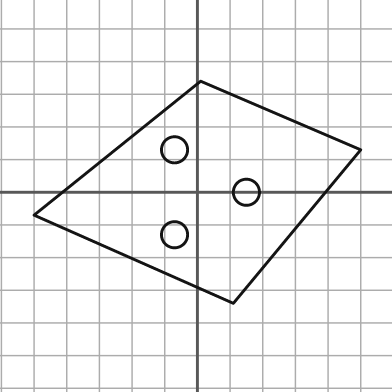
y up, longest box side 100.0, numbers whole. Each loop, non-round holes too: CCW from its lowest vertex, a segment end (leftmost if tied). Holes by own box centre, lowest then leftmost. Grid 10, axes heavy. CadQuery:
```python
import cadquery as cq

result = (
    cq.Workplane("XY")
    .moveTo(11.0, -34.0)
    .lineTo(50.0, 13.0)
    .lineTo(1.0, 34.0)
    .lineTo(-50.0, -7.0)
    .close()
    .moveTo(-7.0, -13.0)
    .circle(4.0)
    .moveTo(15.0, 0.0)
    .circle(4.0)
    .moveTo(-7.0, 13.0)
    .circle(4.0)
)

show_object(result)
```